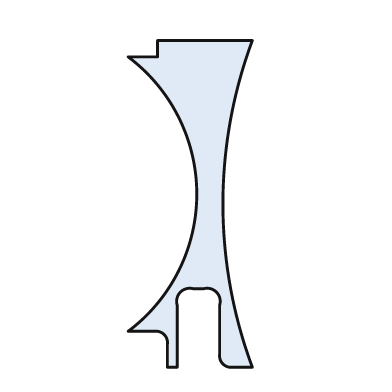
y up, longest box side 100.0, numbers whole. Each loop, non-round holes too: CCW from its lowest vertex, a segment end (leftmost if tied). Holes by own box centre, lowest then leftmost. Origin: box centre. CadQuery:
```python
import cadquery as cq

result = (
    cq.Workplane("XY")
    .moveTo(-7.0, -50.0)
    .lineTo(-4.0, -50.0)
    .lineTo(-4.0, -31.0)
    .threePointArc((-3.0, -27.0), (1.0, -26.0))
    .lineTo(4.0, -26.0)
    .threePointArc((8.0, -27.0), (9.0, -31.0))
    .lineTo(9.0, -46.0)
    .threePointArc((10.0, -49.0), (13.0, -50.0))
    .lineTo(19.0, -50.0)
    .threePointArc((10.0, 0.0), (19.0, 50.0))
    .lineTo(-10.0, 50.0)
    .lineTo(-10.0, 45.0)
    .lineTo(-19.0, 45.0)
    .threePointArc((2.0, 3.0), (-19.0, -39.0))
    .lineTo(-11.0, -39.0)
    .threePointArc((-8.0, -40.0), (-7.0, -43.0))
    .close()
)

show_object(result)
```